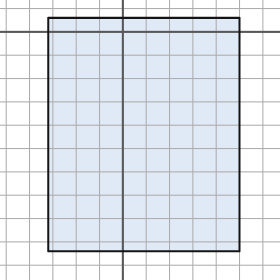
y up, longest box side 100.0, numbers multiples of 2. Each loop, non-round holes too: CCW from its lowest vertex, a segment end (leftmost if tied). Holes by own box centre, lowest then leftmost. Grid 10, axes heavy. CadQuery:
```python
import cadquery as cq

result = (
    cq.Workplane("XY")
    .moveTo(-32.0, -94.0)
    .lineTo(50.0, -94.0)
    .lineTo(50.0, 6.0)
    .lineTo(-32.0, 6.0)
    .close()
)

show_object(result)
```